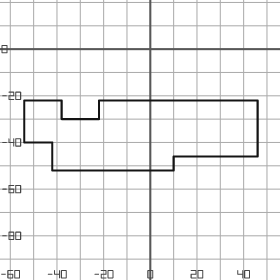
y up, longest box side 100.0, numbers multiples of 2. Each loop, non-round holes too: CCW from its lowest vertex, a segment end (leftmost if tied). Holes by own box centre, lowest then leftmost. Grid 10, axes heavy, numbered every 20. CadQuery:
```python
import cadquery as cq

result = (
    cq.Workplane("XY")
    .moveTo(-42.0, -52.0)
    .lineTo(10.0, -52.0)
    .lineTo(10.0, -46.0)
    .lineTo(46.0, -46.0)
    .lineTo(46.0, -22.0)
    .lineTo(-22.0, -22.0)
    .lineTo(-22.0, -30.0)
    .lineTo(-38.0, -30.0)
    .lineTo(-38.0, -22.0)
    .lineTo(-54.0, -22.0)
    .lineTo(-54.0, -40.0)
    .lineTo(-42.0, -40.0)
    .close()
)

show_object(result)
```